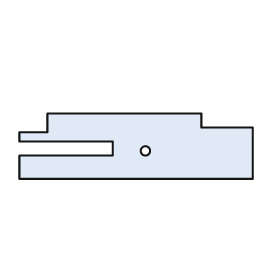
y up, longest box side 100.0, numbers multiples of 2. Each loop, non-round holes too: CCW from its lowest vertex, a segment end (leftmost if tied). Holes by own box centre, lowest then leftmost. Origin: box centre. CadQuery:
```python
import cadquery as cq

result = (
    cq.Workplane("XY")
    .moveTo(-50.0, -14.0)
    .lineTo(50.0, -14.0)
    .lineTo(50.0, 8.0)
    .lineTo(28.0, 8.0)
    .lineTo(28.0, 14.0)
    .lineTo(-38.0, 14.0)
    .lineTo(-38.0, 6.0)
    .lineTo(-50.0, 6.0)
    .lineTo(-50.0, 2.0)
    .lineTo(-10.0, 2.0)
    .lineTo(-10.0, -4.0)
    .lineTo(-50.0, -4.0)
    .close()
    .moveTo(4.0, -2.0)
    .circle(2.0)
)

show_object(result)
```